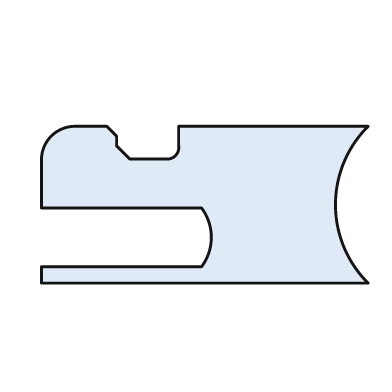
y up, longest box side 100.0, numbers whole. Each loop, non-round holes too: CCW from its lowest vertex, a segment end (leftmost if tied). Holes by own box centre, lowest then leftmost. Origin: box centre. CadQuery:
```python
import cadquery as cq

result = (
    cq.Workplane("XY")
    .moveTo(-50.0, -24.0)
    .lineTo(50.0, -24.0)
    .threePointArc((40.0, 0.0), (50.0, 24.0))
    .lineTo(-8.0, 24.0)
    .lineTo(-8.0, 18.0)
    .threePointArc((-9.0, 15.0), (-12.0, 14.0))
    .lineTo(-23.0, 14.0)
    .lineTo(-27.0, 18.0)
    .lineTo(-27.0, 21.0)
    .lineTo(-30.0, 24.0)
    .lineTo(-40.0, 24.0)
    .threePointArc((-47.0, 21.0), (-50.0, 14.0))
    .lineTo(-50.0, -1.0)
    .lineTo(-1.0, -1.0)
    .threePointArc((2.0, -10.0), (-1.0, -19.0))
    .lineTo(-50.0, -19.0)
    .close()
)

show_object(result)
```